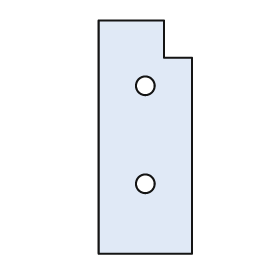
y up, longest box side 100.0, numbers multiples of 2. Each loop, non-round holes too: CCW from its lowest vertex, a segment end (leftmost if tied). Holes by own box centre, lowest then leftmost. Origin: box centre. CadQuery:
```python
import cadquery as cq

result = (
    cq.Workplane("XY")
    .moveTo(-20.0, -50.0)
    .lineTo(20.0, -50.0)
    .lineTo(20.0, 34.0)
    .lineTo(8.0, 34.0)
    .lineTo(8.0, 50.0)
    .lineTo(-20.0, 50.0)
    .close()
    .moveTo(0.0, -20.0)
    .circle(4.0)
    .moveTo(0.0, 22.0)
    .circle(4.0)
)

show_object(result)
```